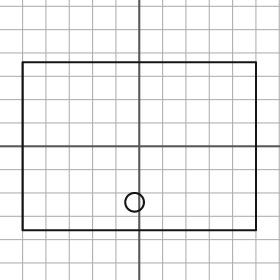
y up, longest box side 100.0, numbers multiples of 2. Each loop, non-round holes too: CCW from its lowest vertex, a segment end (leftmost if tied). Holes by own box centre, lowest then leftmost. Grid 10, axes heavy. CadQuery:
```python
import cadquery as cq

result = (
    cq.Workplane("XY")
    .moveTo(-50.0, -36.0)
    .lineTo(50.0, -36.0)
    .lineTo(50.0, 36.0)
    .lineTo(-50.0, 36.0)
    .close()
    .moveTo(-2.0, -24.0)
    .circle(4.0)
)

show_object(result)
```